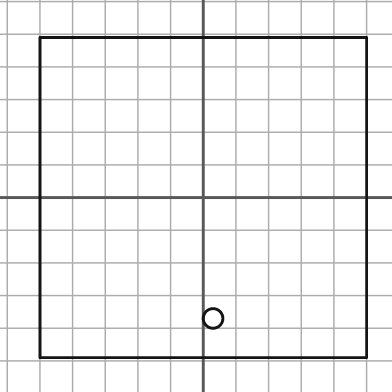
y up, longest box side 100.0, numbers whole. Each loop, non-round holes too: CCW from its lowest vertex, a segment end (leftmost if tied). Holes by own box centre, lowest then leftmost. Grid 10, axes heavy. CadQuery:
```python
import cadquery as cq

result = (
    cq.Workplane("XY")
    .moveTo(-50.0, -49.0)
    .lineTo(50.0, -49.0)
    .lineTo(50.0, 49.0)
    .lineTo(-50.0, 49.0)
    .close()
    .moveTo(3.0, -37.0)
    .circle(3.0)
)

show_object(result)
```